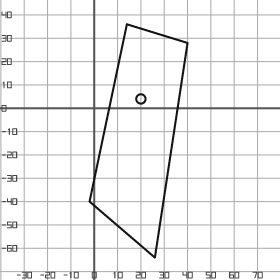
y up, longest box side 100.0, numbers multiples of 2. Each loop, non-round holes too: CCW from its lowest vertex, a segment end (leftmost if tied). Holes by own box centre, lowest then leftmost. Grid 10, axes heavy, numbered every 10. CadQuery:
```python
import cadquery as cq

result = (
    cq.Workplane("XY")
    .moveTo(26.0, -64.0)
    .lineTo(40.0, 28.0)
    .lineTo(14.0, 36.0)
    .lineTo(-2.0, -40.0)
    .close()
    .moveTo(20.0, 4.0)
    .circle(2.0)
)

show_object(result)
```